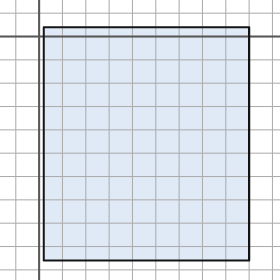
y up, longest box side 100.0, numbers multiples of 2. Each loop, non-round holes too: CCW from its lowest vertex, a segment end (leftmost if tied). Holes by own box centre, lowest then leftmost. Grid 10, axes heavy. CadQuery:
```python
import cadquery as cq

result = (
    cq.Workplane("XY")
    .moveTo(2.0, -96.0)
    .lineTo(90.0, -96.0)
    .lineTo(90.0, 4.0)
    .lineTo(2.0, 4.0)
    .close()
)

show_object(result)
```